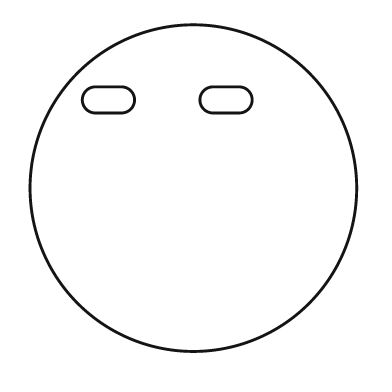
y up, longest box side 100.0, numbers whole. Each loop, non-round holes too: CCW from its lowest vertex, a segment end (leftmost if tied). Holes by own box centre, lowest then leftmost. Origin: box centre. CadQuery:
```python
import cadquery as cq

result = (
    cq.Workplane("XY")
    .moveTo(0.0, 0.0)
    .circle(50.0)
    .moveTo(-30.0, 23.0)
    .lineTo(-22.0, 23.0)
    .threePointArc((-18.0, 27.0), (-22.0, 31.0))
    .lineTo(-30.0, 31.0)
    .threePointArc((-34.0, 27.0), (-30.0, 23.0))
    .close()
    .moveTo(6.0, 23.0)
    .lineTo(14.0, 23.0)
    .threePointArc((18.0, 27.0), (14.0, 31.0))
    .lineTo(6.0, 31.0)
    .threePointArc((2.0, 27.0), (6.0, 23.0))
    .close()
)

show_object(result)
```